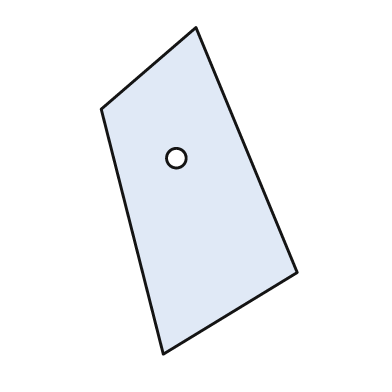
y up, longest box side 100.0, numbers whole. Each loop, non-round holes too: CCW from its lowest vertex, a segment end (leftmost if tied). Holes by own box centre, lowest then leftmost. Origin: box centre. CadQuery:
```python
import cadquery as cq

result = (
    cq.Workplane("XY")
    .moveTo(-11.0, -50.0)
    .lineTo(30.0, -25.0)
    .lineTo(-1.0, 50.0)
    .lineTo(-30.0, 25.0)
    .close()
    .moveTo(-7.0, 10.0)
    .circle(3.0)
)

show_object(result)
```